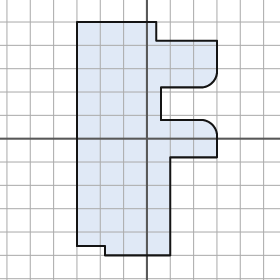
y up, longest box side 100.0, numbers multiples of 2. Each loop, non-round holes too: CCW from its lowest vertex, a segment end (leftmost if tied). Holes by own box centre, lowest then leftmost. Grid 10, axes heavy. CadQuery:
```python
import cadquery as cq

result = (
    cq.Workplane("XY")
    .moveTo(-18.0, -50.0)
    .lineTo(10.0, -50.0)
    .lineTo(10.0, -8.0)
    .lineTo(30.0, -8.0)
    .lineTo(30.0, 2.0)
    .threePointArc((28.0, 6.0), (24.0, 8.0))
    .lineTo(6.0, 8.0)
    .lineTo(6.0, 22.0)
    .lineTo(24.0, 22.0)
    .threePointArc((28.0, 24.0), (30.0, 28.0))
    .lineTo(30.0, 42.0)
    .lineTo(4.0, 42.0)
    .lineTo(4.0, 50.0)
    .lineTo(-30.0, 50.0)
    .lineTo(-30.0, -46.0)
    .lineTo(-18.0, -46.0)
    .close()
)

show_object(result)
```